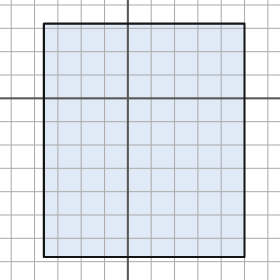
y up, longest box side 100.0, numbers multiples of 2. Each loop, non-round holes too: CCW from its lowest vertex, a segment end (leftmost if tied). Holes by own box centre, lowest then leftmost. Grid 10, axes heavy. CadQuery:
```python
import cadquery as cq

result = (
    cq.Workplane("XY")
    .moveTo(-36.0, -68.0)
    .lineTo(50.0, -68.0)
    .lineTo(50.0, 32.0)
    .lineTo(-36.0, 32.0)
    .close()
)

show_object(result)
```